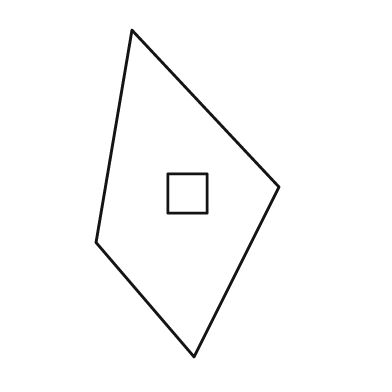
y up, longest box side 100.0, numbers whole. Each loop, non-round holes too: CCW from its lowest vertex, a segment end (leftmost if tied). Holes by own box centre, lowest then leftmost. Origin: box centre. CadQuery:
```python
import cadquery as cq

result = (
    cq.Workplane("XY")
    .moveTo(2.0, -50.0)
    .lineTo(28.0, 2.0)
    .lineTo(-17.0, 50.0)
    .lineTo(-28.0, -15.0)
    .close()
    .moveTo(-6.0, -6.0)
    .lineTo(6.0, -6.0)
    .lineTo(6.0, 6.0)
    .lineTo(-6.0, 6.0)
    .close()
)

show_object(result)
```